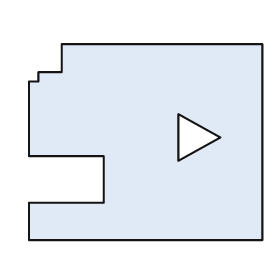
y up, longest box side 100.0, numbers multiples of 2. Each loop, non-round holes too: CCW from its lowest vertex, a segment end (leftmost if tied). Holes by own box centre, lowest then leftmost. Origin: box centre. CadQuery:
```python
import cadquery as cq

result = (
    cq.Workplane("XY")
    .moveTo(-50.0, -42.0)
    .lineTo(50.0, -42.0)
    .lineTo(50.0, 42.0)
    .lineTo(-36.0, 42.0)
    .lineTo(-36.0, 30.0)
    .lineTo(-46.0, 30.0)
    .lineTo(-46.0, 26.0)
    .lineTo(-50.0, 26.0)
    .lineTo(-50.0, -6.0)
    .lineTo(-18.0, -6.0)
    .lineTo(-18.0, -26.0)
    .lineTo(-50.0, -26.0)
    .close()
    .moveTo(14.0, -8.0)
    .lineTo(32.0, 2.0)
    .lineTo(14.0, 12.0)
    .close()
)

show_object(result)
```